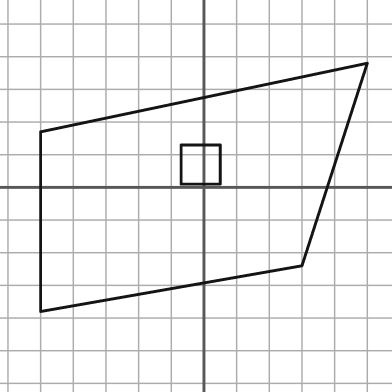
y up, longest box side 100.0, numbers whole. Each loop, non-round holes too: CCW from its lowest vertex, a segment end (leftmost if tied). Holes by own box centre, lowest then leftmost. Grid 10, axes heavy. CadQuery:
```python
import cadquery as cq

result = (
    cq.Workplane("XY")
    .moveTo(-50.0, -38.0)
    .lineTo(30.0, -24.0)
    .lineTo(50.0, 38.0)
    .lineTo(-50.0, 17.0)
    .close()
    .moveTo(-7.0, 1.0)
    .lineTo(5.0, 1.0)
    .lineTo(5.0, 13.0)
    .lineTo(-7.0, 13.0)
    .close()
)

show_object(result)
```